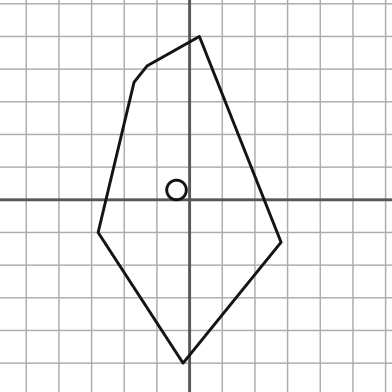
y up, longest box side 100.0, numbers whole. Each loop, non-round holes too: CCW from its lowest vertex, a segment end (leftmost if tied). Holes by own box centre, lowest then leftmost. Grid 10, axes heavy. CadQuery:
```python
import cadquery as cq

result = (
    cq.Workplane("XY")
    .moveTo(-2.0, -50.0)
    .lineTo(28.0, -13.0)
    .lineTo(3.0, 50.0)
    .lineTo(-13.0, 41.0)
    .lineTo(-17.0, 36.0)
    .lineTo(-28.0, -10.0)
    .close()
    .moveTo(-4.0, 3.0)
    .circle(3.0)
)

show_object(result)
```